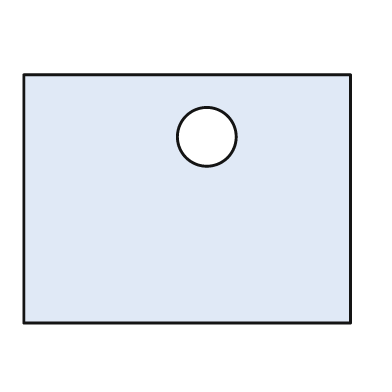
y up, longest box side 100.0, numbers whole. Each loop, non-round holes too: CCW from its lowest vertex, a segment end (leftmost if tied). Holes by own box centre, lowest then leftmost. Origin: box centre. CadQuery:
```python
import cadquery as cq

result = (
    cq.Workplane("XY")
    .moveTo(-50.0, -38.0)
    .lineTo(50.0, -38.0)
    .lineTo(50.0, 38.0)
    .lineTo(-50.0, 38.0)
    .close()
    .moveTo(6.0, 19.0)
    .circle(9.0)
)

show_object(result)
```